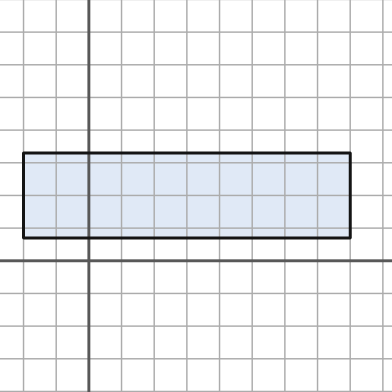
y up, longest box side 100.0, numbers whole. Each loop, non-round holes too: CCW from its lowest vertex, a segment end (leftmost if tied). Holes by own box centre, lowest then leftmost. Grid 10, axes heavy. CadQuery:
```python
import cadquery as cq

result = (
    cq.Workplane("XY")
    .moveTo(-20.0, 7.0)
    .lineTo(80.0, 7.0)
    .lineTo(80.0, 33.0)
    .lineTo(-20.0, 33.0)
    .close()
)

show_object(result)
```